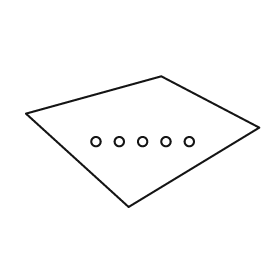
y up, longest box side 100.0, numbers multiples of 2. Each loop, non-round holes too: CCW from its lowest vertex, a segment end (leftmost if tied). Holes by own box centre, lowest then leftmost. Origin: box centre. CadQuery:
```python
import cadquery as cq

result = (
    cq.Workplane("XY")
    .moveTo(-6.0, -28.0)
    .lineTo(50.0, 6.0)
    .lineTo(8.0, 28.0)
    .lineTo(-50.0, 12.0)
    .close()
    .moveTo(-20.0, 0.0)
    .circle(2.0)
    .moveTo(-10.0, 0.0)
    .circle(2.0)
    .moveTo(0.0, 0.0)
    .circle(2.0)
    .moveTo(10.0, 0.0)
    .circle(2.0)
    .moveTo(20.0, 0.0)
    .circle(2.0)
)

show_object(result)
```